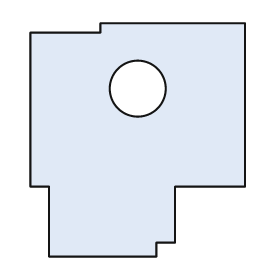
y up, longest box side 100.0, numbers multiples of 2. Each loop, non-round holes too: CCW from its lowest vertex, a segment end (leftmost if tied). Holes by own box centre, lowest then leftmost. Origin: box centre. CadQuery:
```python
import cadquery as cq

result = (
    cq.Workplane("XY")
    .moveTo(-38.0, -50.0)
    .lineTo(8.0, -50.0)
    .lineTo(8.0, -44.0)
    .lineTo(16.0, -44.0)
    .lineTo(16.0, -20.0)
    .lineTo(46.0, -20.0)
    .lineTo(46.0, 50.0)
    .lineTo(-16.0, 50.0)
    .lineTo(-16.0, 46.0)
    .lineTo(-46.0, 46.0)
    .lineTo(-46.0, -20.0)
    .lineTo(-38.0, -20.0)
    .close()
    .moveTo(0.0, 22.0)
    .circle(12.0)
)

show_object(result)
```